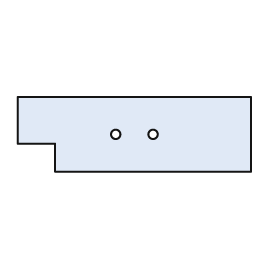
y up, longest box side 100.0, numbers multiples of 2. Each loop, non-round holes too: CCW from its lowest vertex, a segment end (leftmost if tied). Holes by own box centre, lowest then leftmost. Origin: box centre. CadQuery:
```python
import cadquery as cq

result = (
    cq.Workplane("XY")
    .moveTo(-34.0, -16.0)
    .lineTo(50.0, -16.0)
    .lineTo(50.0, 16.0)
    .lineTo(-50.0, 16.0)
    .lineTo(-50.0, -4.0)
    .lineTo(-34.0, -4.0)
    .close()
    .moveTo(-8.0, 0.0)
    .circle(2.0)
    .moveTo(8.0, 0.0)
    .circle(2.0)
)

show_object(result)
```